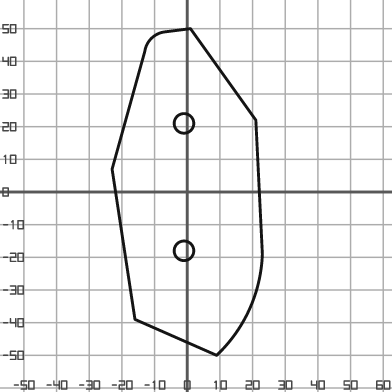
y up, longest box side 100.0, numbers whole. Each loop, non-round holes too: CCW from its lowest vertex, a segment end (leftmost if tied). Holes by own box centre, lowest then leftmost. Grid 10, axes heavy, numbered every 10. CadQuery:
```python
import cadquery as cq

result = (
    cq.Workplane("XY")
    .moveTo(9.0, -50.0)
    .threePointArc((19.0, -36.0), (23.0, -19.0))
    .lineTo(21.0, 22.0)
    .lineTo(1.0, 50.0)
    .lineTo(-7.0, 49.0)
    .threePointArc((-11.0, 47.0), (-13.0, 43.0))
    .lineTo(-23.0, 7.0)
    .lineTo(-16.0, -39.0)
    .close()
    .moveTo(-1.0, -18.0)
    .circle(3.0)
    .moveTo(-1.0, 21.0)
    .circle(3.0)
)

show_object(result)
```